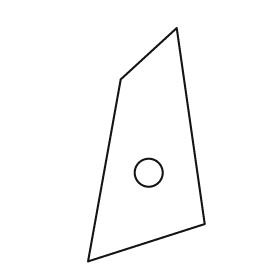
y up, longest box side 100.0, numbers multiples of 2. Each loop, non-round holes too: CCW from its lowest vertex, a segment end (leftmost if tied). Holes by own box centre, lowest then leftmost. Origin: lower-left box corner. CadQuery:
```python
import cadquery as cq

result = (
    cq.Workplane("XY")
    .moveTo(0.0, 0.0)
    .lineTo(50.0, 16.0)
    .lineTo(38.0, 100.0)
    .lineTo(14.0, 78.0)
    .close()
    .moveTo(26.0, 38.0)
    .circle(6.0)
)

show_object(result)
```